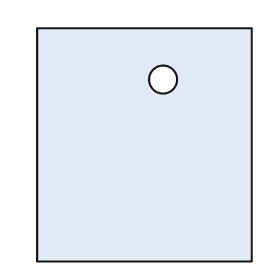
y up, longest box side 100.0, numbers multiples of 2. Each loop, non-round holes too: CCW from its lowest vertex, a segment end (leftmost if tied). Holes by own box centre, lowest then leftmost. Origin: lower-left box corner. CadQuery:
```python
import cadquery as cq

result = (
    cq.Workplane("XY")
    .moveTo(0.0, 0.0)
    .lineTo(92.0, 0.0)
    .lineTo(92.0, 100.0)
    .lineTo(0.0, 100.0)
    .close()
    .moveTo(54.0, 78.0)
    .circle(6.0)
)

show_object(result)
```